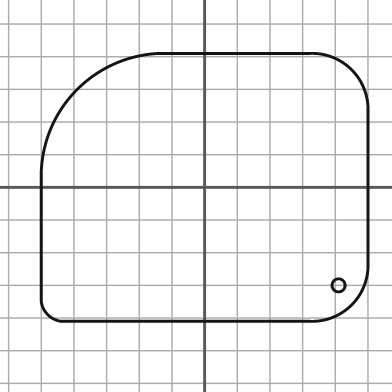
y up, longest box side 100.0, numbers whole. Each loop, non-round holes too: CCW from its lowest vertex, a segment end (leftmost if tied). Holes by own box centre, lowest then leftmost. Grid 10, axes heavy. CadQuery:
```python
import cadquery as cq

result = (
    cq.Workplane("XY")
    .moveTo(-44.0, -41.0)
    .lineTo(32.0, -41.0)
    .threePointArc((45.0, -36.0), (50.0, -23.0))
    .lineTo(50.0, 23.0)
    .threePointArc((45.0, 36.0), (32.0, 41.0))
    .lineTo(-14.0, 41.0)
    .threePointArc((-39.0, 30.0), (-50.0, 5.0))
    .lineTo(-50.0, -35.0)
    .threePointArc((-48.0, -39.0), (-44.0, -41.0))
    .close()
    .moveTo(41.0, -30.0)
    .circle(2.0)
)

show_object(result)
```